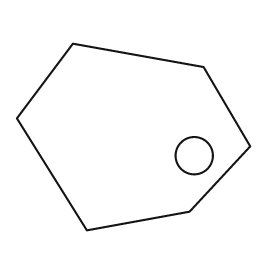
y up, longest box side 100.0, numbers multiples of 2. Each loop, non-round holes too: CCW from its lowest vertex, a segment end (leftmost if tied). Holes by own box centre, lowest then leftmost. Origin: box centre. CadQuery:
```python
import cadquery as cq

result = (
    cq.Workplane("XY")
    .moveTo(-20.0, -40.0)
    .lineTo(24.0, -32.0)
    .lineTo(50.0, -4.0)
    .lineTo(30.0, 30.0)
    .lineTo(-26.0, 40.0)
    .lineTo(-50.0, 8.0)
    .close()
    .moveTo(26.0, -8.0)
    .circle(8.0)
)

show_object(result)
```